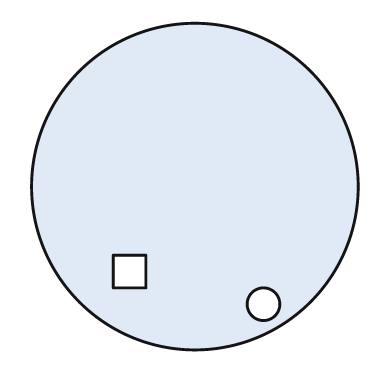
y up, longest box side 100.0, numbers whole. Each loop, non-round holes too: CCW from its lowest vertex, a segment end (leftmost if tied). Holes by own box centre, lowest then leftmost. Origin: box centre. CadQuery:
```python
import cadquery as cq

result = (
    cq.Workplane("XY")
    .moveTo(0.0, 0.0)
    .circle(50.0)
    .moveTo(21.0, -36.0)
    .circle(5.0)
    .moveTo(-25.0, -31.0)
    .lineTo(-15.0, -31.0)
    .lineTo(-15.0, -21.0)
    .lineTo(-25.0, -21.0)
    .close()
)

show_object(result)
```